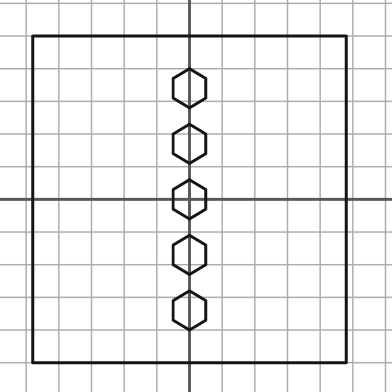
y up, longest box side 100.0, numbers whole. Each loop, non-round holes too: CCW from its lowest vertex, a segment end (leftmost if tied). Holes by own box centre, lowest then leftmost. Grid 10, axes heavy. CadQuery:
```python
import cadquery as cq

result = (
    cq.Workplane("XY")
    .moveTo(-48.0, -50.0)
    .lineTo(48.0, -50.0)
    .lineTo(48.0, 50.0)
    .lineTo(-48.0, 50.0)
    .close()
    .moveTo(0.0, -40.0)
    .lineTo(5.0, -37.0)
    .lineTo(5.0, -31.0)
    .lineTo(0.0, -28.0)
    .lineTo(-5.0, -31.0)
    .lineTo(-5.0, -37.0)
    .close()
    .moveTo(0.0, -23.0)
    .lineTo(5.0, -20.0)
    .lineTo(5.0, -14.0)
    .lineTo(0.0, -11.0)
    .lineTo(-5.0, -14.0)
    .lineTo(-5.0, -20.0)
    .close()
    .moveTo(0.0, -6.0)
    .lineTo(5.0, -3.0)
    .lineTo(5.0, 3.0)
    .lineTo(0.0, 6.0)
    .lineTo(-5.0, 3.0)
    .lineTo(-5.0, -3.0)
    .close()
    .moveTo(0.0, 11.0)
    .lineTo(5.0, 14.0)
    .lineTo(5.0, 20.0)
    .lineTo(0.0, 23.0)
    .lineTo(-5.0, 20.0)
    .lineTo(-5.0, 14.0)
    .close()
    .moveTo(0.0, 28.0)
    .lineTo(5.0, 31.0)
    .lineTo(5.0, 37.0)
    .lineTo(0.0, 40.0)
    .lineTo(-5.0, 37.0)
    .lineTo(-5.0, 31.0)
    .close()
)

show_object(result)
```